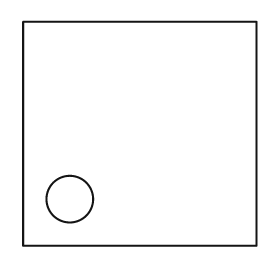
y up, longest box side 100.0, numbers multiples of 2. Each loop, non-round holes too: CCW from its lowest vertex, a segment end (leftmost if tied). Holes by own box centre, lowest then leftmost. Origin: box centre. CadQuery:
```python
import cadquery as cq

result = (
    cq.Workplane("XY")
    .moveTo(-50.0, -48.0)
    .lineTo(50.0, -48.0)
    .lineTo(50.0, 48.0)
    .lineTo(-50.0, 48.0)
    .close()
    .moveTo(-30.0, -28.0)
    .circle(10.0)
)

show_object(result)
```